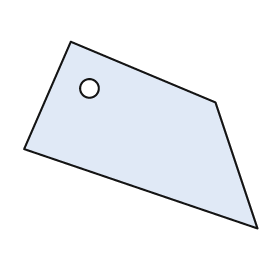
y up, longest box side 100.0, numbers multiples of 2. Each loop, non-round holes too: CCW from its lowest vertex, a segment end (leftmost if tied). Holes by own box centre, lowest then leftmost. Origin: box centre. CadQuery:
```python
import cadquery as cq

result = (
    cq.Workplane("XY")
    .moveTo(50.0, -40.0)
    .lineTo(32.0, 14.0)
    .lineTo(-30.0, 40.0)
    .lineTo(-50.0, -6.0)
    .close()
    .moveTo(-22.0, 20.0)
    .circle(4.0)
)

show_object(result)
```